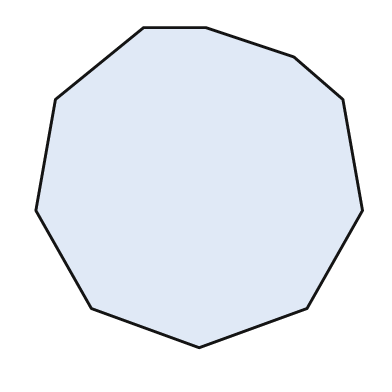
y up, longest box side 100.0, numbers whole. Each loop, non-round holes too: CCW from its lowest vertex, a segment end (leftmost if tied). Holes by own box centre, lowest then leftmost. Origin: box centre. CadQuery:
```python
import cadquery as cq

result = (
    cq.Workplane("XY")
    .moveTo(0.0, -49.0)
    .lineTo(33.0, -37.0)
    .lineTo(50.0, -7.0)
    .lineTo(44.0, 27.0)
    .lineTo(29.0, 40.0)
    .lineTo(2.0, 49.0)
    .lineTo(-17.0, 49.0)
    .lineTo(-44.0, 27.0)
    .lineTo(-50.0, -7.0)
    .lineTo(-33.0, -37.0)
    .close()
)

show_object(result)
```